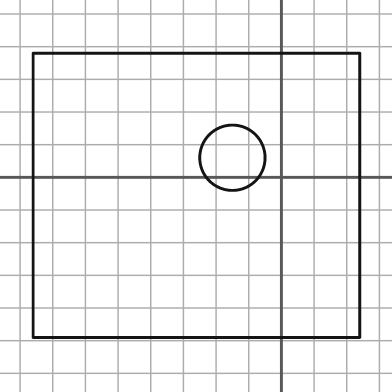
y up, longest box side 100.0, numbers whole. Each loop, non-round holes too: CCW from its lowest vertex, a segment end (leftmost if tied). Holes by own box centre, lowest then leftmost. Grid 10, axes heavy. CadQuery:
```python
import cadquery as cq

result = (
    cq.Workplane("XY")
    .moveTo(-76.0, -49.0)
    .lineTo(24.0, -49.0)
    .lineTo(24.0, 38.0)
    .lineTo(-76.0, 38.0)
    .close()
    .moveTo(-15.0, 6.0)
    .circle(10.0)
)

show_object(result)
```